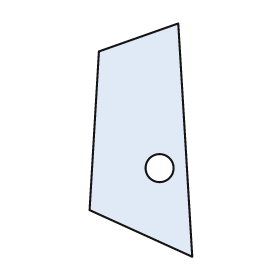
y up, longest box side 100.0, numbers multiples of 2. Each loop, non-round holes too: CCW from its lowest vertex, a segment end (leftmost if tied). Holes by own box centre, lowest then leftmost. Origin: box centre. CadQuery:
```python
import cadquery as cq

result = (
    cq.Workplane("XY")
    .moveTo(22.0, -50.0)
    .lineTo(16.0, 50.0)
    .lineTo(-18.0, 38.0)
    .lineTo(-22.0, -30.0)
    .close()
    .moveTo(8.0, -12.0)
    .circle(6.0)
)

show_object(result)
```